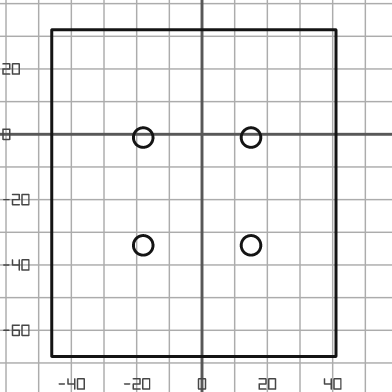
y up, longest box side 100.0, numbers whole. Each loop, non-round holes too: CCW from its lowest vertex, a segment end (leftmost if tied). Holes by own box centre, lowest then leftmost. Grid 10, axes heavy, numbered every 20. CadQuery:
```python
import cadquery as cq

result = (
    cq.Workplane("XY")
    .moveTo(-46.0, -68.0)
    .lineTo(41.0, -68.0)
    .lineTo(41.0, 32.0)
    .lineTo(-46.0, 32.0)
    .close()
    .moveTo(-18.0, -34.0)
    .circle(3.0)
    .moveTo(15.0, -34.0)
    .circle(3.0)
    .moveTo(-18.0, -1.0)
    .circle(3.0)
    .moveTo(15.0, -1.0)
    .circle(3.0)
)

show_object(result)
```